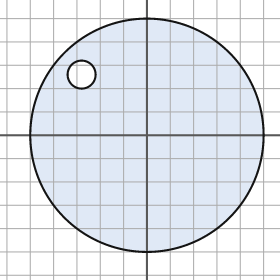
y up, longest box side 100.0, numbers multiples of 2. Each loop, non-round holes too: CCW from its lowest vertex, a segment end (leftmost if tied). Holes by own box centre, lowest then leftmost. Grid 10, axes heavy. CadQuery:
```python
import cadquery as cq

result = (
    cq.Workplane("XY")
    .moveTo(0.0, 0.0)
    .circle(50.0)
    .moveTo(-28.0, 26.0)
    .circle(6.0)
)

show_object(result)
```